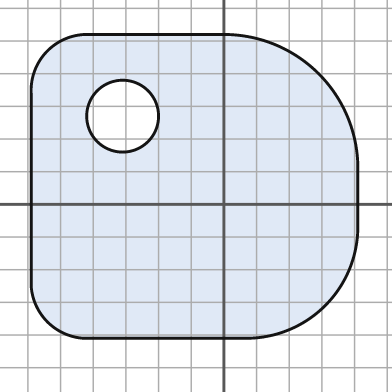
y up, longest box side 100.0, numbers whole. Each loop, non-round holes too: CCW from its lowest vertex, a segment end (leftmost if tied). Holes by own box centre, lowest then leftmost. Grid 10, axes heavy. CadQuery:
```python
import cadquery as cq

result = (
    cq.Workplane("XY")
    .moveTo(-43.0, -41.0)
    .lineTo(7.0, -41.0)
    .threePointArc((31.0, -31.0), (41.0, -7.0))
    .lineTo(41.0, 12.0)
    .threePointArc((29.0, 40.0), (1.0, 52.0))
    .lineTo(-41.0, 52.0)
    .threePointArc((-54.0, 47.0), (-59.0, 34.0))
    .lineTo(-59.0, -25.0)
    .threePointArc((-54.0, -36.0), (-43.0, -41.0))
    .close()
    .moveTo(-31.0, 27.0)
    .circle(11.0)
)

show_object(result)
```